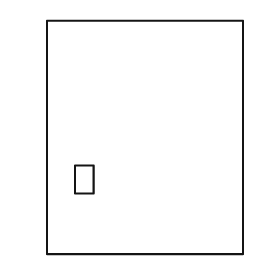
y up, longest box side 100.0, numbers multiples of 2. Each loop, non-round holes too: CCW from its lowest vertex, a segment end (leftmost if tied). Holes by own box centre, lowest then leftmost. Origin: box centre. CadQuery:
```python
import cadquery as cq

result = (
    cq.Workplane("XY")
    .moveTo(-42.0, -50.0)
    .lineTo(42.0, -50.0)
    .lineTo(42.0, 50.0)
    .lineTo(-42.0, 50.0)
    .close()
    .moveTo(-30.0, -24.0)
    .lineTo(-22.0, -24.0)
    .lineTo(-22.0, -12.0)
    .lineTo(-30.0, -12.0)
    .close()
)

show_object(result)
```